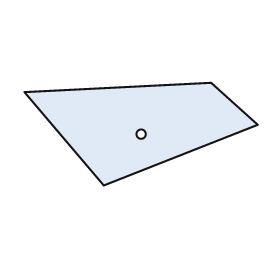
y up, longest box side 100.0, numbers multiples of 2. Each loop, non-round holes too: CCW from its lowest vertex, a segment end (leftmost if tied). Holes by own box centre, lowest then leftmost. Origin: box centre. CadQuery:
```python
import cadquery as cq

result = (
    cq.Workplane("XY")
    .moveTo(-16.0, -22.0)
    .lineTo(50.0, 4.0)
    .lineTo(30.0, 22.0)
    .lineTo(-50.0, 18.0)
    .close()
    .moveTo(0.0, 0.0)
    .circle(2.0)
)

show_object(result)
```